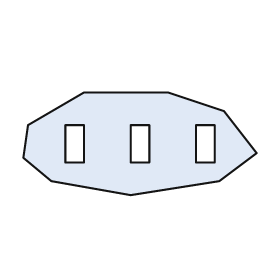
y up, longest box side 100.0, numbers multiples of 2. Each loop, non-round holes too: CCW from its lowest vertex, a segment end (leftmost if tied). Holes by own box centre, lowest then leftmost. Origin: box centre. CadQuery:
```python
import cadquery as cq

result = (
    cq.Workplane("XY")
    .moveTo(-4.0, -22.0)
    .lineTo(34.0, -16.0)
    .lineTo(50.0, -4.0)
    .lineTo(36.0, 14.0)
    .lineTo(12.0, 22.0)
    .lineTo(-24.0, 22.0)
    .lineTo(-48.0, 8.0)
    .lineTo(-50.0, -6.0)
    .lineTo(-38.0, -16.0)
    .close()
    .moveTo(-32.0, -8.0)
    .lineTo(-24.0, -8.0)
    .lineTo(-24.0, 8.0)
    .lineTo(-32.0, 8.0)
    .close()
    .moveTo(-4.0, -8.0)
    .lineTo(4.0, -8.0)
    .lineTo(4.0, 8.0)
    .lineTo(-4.0, 8.0)
    .close()
    .moveTo(24.0, -8.0)
    .lineTo(32.0, -8.0)
    .lineTo(32.0, 8.0)
    .lineTo(24.0, 8.0)
    .close()
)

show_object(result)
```